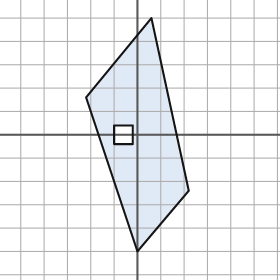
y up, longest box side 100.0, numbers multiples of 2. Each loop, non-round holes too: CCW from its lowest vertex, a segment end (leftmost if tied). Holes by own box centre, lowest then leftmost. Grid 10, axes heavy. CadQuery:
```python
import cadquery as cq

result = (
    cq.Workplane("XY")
    .moveTo(0.0, -50.0)
    .lineTo(22.0, -24.0)
    .lineTo(6.0, 50.0)
    .lineTo(-22.0, 16.0)
    .close()
    .moveTo(-10.0, -4.0)
    .lineTo(-2.0, -4.0)
    .lineTo(-2.0, 4.0)
    .lineTo(-10.0, 4.0)
    .close()
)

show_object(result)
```